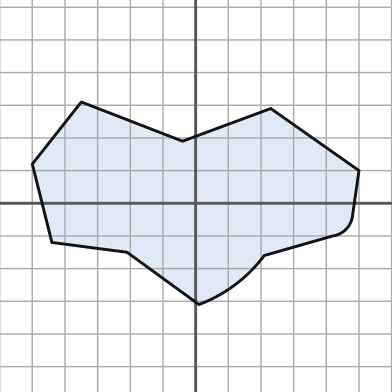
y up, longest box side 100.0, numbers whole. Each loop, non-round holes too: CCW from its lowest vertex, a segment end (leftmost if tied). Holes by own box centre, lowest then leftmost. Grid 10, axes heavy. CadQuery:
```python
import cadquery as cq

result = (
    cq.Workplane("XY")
    .moveTo(1.0, -31.0)
    .threePointArc((12.0, -25.0), (21.0, -16.0))
    .lineTo(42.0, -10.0)
    .threePointArc((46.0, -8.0), (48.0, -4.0))
    .lineTo(50.0, 10.0)
    .lineTo(23.0, 29.0)
    .lineTo(-4.0, 19.0)
    .lineTo(-35.0, 31.0)
    .lineTo(-50.0, 12.0)
    .lineTo(-44.0, -12.0)
    .lineTo(-21.0, -15.0)
    .close()
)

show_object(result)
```